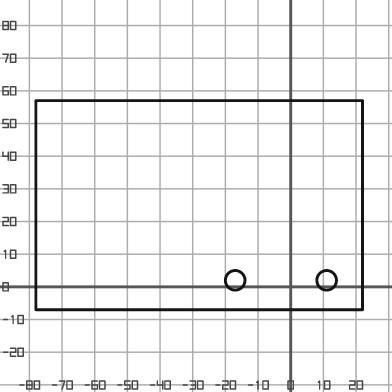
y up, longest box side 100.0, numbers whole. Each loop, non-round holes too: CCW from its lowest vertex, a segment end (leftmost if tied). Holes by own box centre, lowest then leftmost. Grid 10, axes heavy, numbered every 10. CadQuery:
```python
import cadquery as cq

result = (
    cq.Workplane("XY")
    .moveTo(-78.0, -7.0)
    .lineTo(22.0, -7.0)
    .lineTo(22.0, 57.0)
    .lineTo(-78.0, 57.0)
    .close()
    .moveTo(-17.0, 2.0)
    .circle(3.0)
    .moveTo(11.0, 2.0)
    .circle(3.0)
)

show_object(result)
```